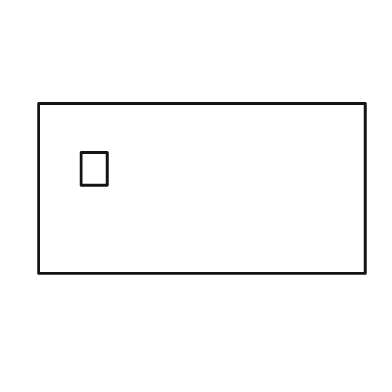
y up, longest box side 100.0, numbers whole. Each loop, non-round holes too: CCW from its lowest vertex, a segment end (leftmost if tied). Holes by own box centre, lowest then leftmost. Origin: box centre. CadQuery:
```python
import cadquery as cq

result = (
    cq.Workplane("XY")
    .moveTo(-50.0, -26.0)
    .lineTo(50.0, -26.0)
    .lineTo(50.0, 26.0)
    .lineTo(-50.0, 26.0)
    .close()
    .moveTo(-37.0, 1.0)
    .lineTo(-29.0, 1.0)
    .lineTo(-29.0, 11.0)
    .lineTo(-37.0, 11.0)
    .close()
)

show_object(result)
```